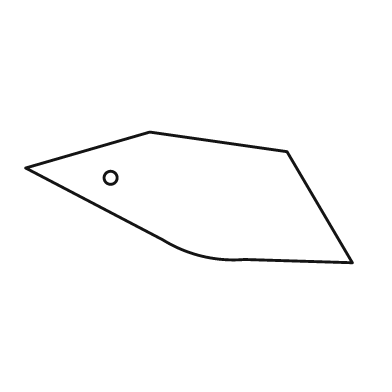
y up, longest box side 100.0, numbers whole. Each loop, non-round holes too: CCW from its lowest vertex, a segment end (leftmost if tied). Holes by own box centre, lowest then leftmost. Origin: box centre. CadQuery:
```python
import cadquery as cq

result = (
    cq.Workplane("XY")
    .moveTo(50.0, -20.0)
    .lineTo(30.0, 14.0)
    .lineTo(-12.0, 20.0)
    .lineTo(-50.0, 9.0)
    .lineTo(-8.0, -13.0)
    .threePointArc((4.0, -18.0), (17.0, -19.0))
    .close()
    .moveTo(-24.0, 6.0)
    .circle(2.0)
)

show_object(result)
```